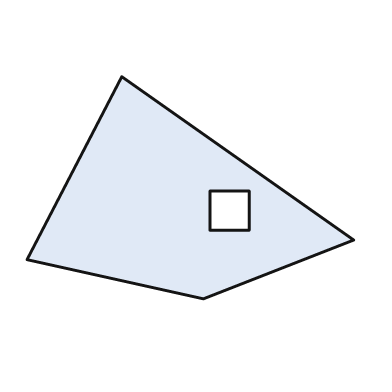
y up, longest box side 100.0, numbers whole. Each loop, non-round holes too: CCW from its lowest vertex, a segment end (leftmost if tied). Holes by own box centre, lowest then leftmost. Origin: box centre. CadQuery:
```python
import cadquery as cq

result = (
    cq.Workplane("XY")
    .moveTo(4.0, -34.0)
    .lineTo(50.0, -16.0)
    .lineTo(-21.0, 34.0)
    .lineTo(-50.0, -22.0)
    .close()
    .moveTo(6.0, -13.0)
    .lineTo(18.0, -13.0)
    .lineTo(18.0, -1.0)
    .lineTo(6.0, -1.0)
    .close()
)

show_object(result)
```